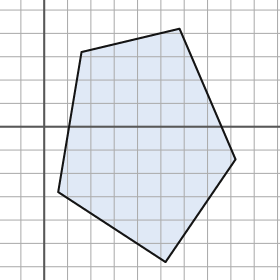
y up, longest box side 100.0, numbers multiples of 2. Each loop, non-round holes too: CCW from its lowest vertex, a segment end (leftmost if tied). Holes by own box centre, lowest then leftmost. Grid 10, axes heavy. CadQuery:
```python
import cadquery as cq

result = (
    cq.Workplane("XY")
    .moveTo(52.0, -58.0)
    .lineTo(82.0, -14.0)
    .lineTo(58.0, 42.0)
    .lineTo(16.0, 32.0)
    .lineTo(6.0, -28.0)
    .close()
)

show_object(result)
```